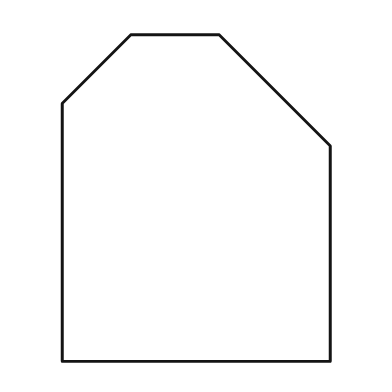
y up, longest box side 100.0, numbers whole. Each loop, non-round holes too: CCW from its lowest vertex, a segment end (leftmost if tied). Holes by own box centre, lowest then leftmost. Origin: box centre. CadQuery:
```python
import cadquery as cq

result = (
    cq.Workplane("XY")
    .moveTo(-41.0, -50.0)
    .lineTo(41.0, -50.0)
    .lineTo(41.0, 16.0)
    .lineTo(7.0, 50.0)
    .lineTo(-20.0, 50.0)
    .lineTo(-41.0, 29.0)
    .close()
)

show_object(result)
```